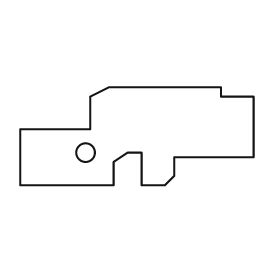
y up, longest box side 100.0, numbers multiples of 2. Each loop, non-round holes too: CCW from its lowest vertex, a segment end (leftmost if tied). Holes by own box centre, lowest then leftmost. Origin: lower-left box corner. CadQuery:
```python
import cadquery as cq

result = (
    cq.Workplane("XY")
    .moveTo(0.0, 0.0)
    .lineTo(40.0, 0.0)
    .lineTo(40.0, 10.0)
    .lineTo(46.0, 14.0)
    .lineTo(52.0, 14.0)
    .lineTo(52.0, 0.0)
    .lineTo(62.0, 0.0)
    .lineTo(66.0, 4.0)
    .lineTo(66.0, 12.0)
    .lineTo(100.0, 12.0)
    .lineTo(100.0, 38.0)
    .lineTo(86.0, 38.0)
    .lineTo(86.0, 42.0)
    .lineTo(38.0, 42.0)
    .lineTo(30.0, 38.0)
    .lineTo(30.0, 24.0)
    .lineTo(0.0, 24.0)
    .close()
    .moveTo(28.0, 14.0)
    .circle(4.0)
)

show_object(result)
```